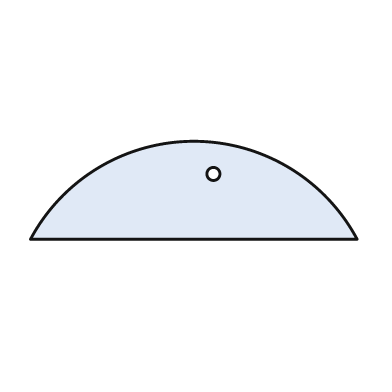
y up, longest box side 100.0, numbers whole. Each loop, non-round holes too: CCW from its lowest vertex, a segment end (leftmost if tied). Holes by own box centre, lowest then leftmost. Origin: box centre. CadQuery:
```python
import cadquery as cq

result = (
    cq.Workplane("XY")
    .moveTo(-50.0, -15.0)
    .lineTo(50.0, -15.0)
    .threePointArc((0.0, 15.0), (-50.0, -15.0))
    .close()
    .moveTo(6.0, 5.0)
    .circle(2.0)
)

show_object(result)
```